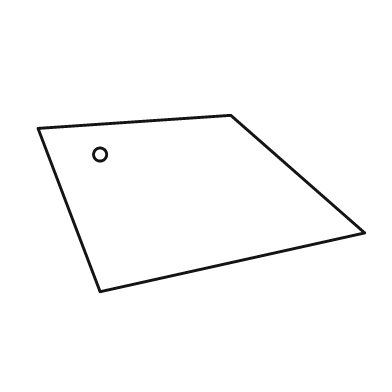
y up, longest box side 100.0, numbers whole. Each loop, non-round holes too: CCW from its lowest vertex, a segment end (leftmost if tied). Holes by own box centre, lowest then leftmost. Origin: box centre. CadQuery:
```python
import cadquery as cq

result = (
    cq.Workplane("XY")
    .moveTo(-31.0, -27.0)
    .lineTo(50.0, -9.0)
    .lineTo(9.0, 27.0)
    .lineTo(-50.0, 23.0)
    .close()
    .moveTo(-31.0, 15.0)
    .circle(2.0)
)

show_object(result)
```